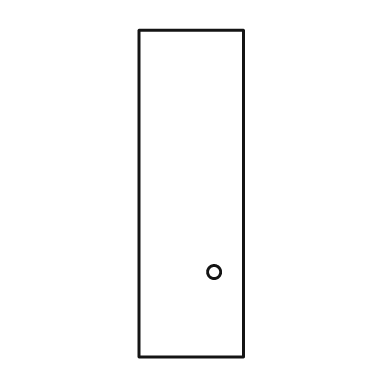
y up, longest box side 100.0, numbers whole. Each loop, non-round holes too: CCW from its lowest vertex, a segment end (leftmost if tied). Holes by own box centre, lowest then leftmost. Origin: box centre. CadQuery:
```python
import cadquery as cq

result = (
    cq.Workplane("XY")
    .moveTo(-16.0, -50.0)
    .lineTo(16.0, -50.0)
    .lineTo(16.0, 50.0)
    .lineTo(-16.0, 50.0)
    .close()
    .moveTo(7.0, -24.0)
    .circle(2.0)
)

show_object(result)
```